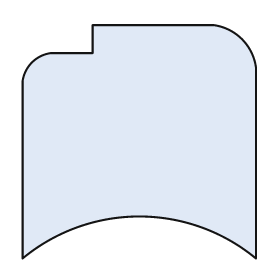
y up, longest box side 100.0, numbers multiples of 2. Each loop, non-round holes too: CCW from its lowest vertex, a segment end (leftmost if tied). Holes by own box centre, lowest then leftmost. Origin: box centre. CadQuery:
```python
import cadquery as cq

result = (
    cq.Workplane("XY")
    .moveTo(-50.0, -50.0)
    .threePointArc((0.0, -32.0), (50.0, -50.0))
    .lineTo(50.0, 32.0)
    .threePointArc((44.0, 44.0), (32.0, 50.0))
    .lineTo(-20.0, 50.0)
    .lineTo(-20.0, 38.0)
    .lineTo(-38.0, 38.0)
    .threePointArc((-46.0, 34.0), (-50.0, 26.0))
    .close()
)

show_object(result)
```